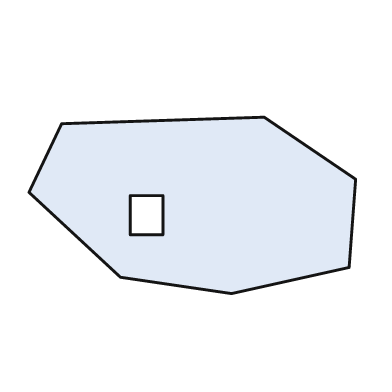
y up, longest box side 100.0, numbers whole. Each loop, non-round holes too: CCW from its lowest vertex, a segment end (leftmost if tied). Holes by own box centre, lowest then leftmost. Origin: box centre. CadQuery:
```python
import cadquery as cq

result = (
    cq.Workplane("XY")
    .moveTo(12.0, -27.0)
    .lineTo(48.0, -19.0)
    .lineTo(50.0, 8.0)
    .lineTo(22.0, 27.0)
    .lineTo(-40.0, 25.0)
    .lineTo(-50.0, 4.0)
    .lineTo(-22.0, -22.0)
    .close()
    .moveTo(-19.0, -9.0)
    .lineTo(-9.0, -9.0)
    .lineTo(-9.0, 3.0)
    .lineTo(-19.0, 3.0)
    .close()
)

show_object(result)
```